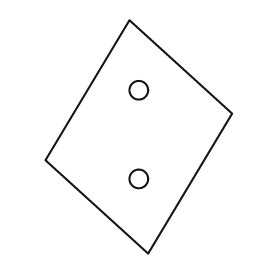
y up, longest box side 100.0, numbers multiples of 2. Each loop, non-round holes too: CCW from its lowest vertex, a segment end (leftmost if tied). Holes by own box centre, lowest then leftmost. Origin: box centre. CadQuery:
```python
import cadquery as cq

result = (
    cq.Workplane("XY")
    .moveTo(4.0, -50.0)
    .lineTo(40.0, 10.0)
    .lineTo(-4.0, 50.0)
    .lineTo(-40.0, -10.0)
    .close()
    .moveTo(0.0, -18.0)
    .circle(4.0)
    .moveTo(0.0, 20.0)
    .circle(4.0)
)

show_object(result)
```